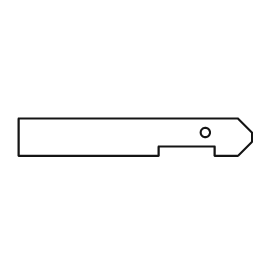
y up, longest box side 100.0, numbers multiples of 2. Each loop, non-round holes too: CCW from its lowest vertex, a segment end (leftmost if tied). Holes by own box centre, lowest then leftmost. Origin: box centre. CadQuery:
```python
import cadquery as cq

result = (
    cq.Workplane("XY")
    .moveTo(-50.0, -8.0)
    .lineTo(10.0, -8.0)
    .lineTo(10.0, -4.0)
    .lineTo(34.0, -4.0)
    .lineTo(34.0, -8.0)
    .lineTo(44.0, -8.0)
    .lineTo(50.0, -2.0)
    .lineTo(50.0, 2.0)
    .lineTo(44.0, 8.0)
    .lineTo(-50.0, 8.0)
    .close()
    .moveTo(30.0, 2.0)
    .circle(2.0)
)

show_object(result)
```